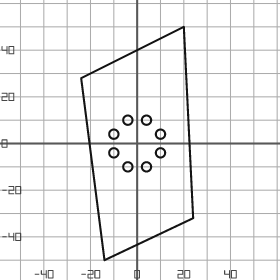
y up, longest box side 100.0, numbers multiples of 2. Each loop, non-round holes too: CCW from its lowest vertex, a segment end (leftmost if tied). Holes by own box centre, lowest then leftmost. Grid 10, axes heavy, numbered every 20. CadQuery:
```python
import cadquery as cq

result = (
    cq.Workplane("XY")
    .moveTo(-14.0, -50.0)
    .lineTo(24.0, -32.0)
    .lineTo(20.0, 50.0)
    .lineTo(-24.0, 28.0)
    .close()
    .moveTo(-4.0, -10.0)
    .circle(2.0)
    .moveTo(4.0, -10.0)
    .circle(2.0)
    .moveTo(-10.0, -4.0)
    .circle(2.0)
    .moveTo(10.0, -4.0)
    .circle(2.0)
    .moveTo(-10.0, 4.0)
    .circle(2.0)
    .moveTo(10.0, 4.0)
    .circle(2.0)
    .moveTo(-4.0, 10.0)
    .circle(2.0)
    .moveTo(4.0, 10.0)
    .circle(2.0)
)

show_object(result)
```